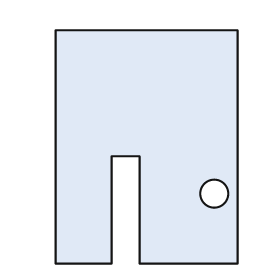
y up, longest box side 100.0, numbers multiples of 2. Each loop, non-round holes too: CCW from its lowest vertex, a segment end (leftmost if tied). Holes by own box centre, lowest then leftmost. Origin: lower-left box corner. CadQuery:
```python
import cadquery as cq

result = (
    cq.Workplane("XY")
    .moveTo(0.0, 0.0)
    .lineTo(24.0, 0.0)
    .lineTo(24.0, 46.0)
    .lineTo(36.0, 46.0)
    .lineTo(36.0, 0.0)
    .lineTo(78.0, 0.0)
    .lineTo(78.0, 100.0)
    .lineTo(0.0, 100.0)
    .close()
    .moveTo(68.0, 30.0)
    .circle(6.0)
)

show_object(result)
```